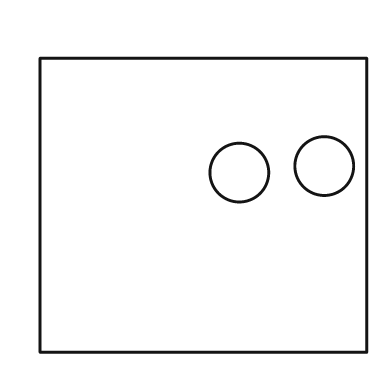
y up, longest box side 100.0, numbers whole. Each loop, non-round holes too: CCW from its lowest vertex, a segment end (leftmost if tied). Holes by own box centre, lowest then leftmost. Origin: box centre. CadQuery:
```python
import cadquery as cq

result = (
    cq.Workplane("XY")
    .moveTo(-50.0, -45.0)
    .lineTo(50.0, -45.0)
    .lineTo(50.0, 45.0)
    .lineTo(-50.0, 45.0)
    .close()
    .moveTo(11.0, 10.0)
    .circle(9.0)
    .moveTo(37.0, 12.0)
    .circle(9.0)
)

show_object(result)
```